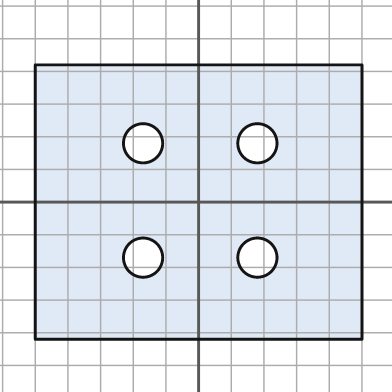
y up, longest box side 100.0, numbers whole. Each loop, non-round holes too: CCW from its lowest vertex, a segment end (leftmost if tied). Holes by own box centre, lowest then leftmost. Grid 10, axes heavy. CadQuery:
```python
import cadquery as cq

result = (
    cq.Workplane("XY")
    .moveTo(-50.0, -42.0)
    .lineTo(50.0, -42.0)
    .lineTo(50.0, 42.0)
    .lineTo(-50.0, 42.0)
    .close()
    .moveTo(-17.0, -17.0)
    .circle(6.0)
    .moveTo(18.0, -17.0)
    .circle(6.0)
    .moveTo(-17.0, 18.0)
    .circle(6.0)
    .moveTo(18.0, 18.0)
    .circle(6.0)
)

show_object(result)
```